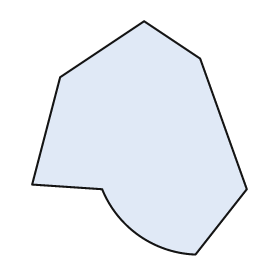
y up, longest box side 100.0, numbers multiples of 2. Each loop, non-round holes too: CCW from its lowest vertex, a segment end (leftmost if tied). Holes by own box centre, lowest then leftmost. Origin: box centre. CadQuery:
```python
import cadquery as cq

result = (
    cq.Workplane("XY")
    .moveTo(24.0, -50.0)
    .lineTo(46.0, -22.0)
    .lineTo(26.0, 34.0)
    .lineTo(2.0, 50.0)
    .lineTo(-34.0, 26.0)
    .lineTo(-46.0, -20.0)
    .lineTo(-16.0, -22.0)
    .threePointArc((0.0, -42.0), (24.0, -50.0))
    .close()
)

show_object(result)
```